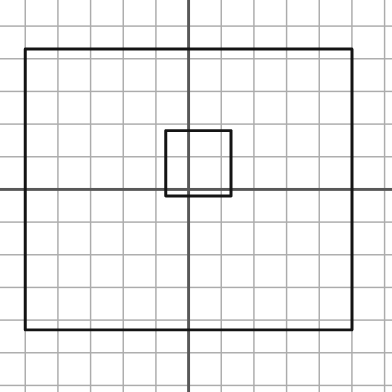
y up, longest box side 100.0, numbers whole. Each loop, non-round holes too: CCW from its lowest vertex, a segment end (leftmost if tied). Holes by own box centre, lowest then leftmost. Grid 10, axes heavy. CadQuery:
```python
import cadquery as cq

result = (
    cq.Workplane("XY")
    .moveTo(-50.0, -43.0)
    .lineTo(50.0, -43.0)
    .lineTo(50.0, 43.0)
    .lineTo(-50.0, 43.0)
    .close()
    .moveTo(-7.0, -2.0)
    .lineTo(13.0, -2.0)
    .lineTo(13.0, 18.0)
    .lineTo(-7.0, 18.0)
    .close()
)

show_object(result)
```